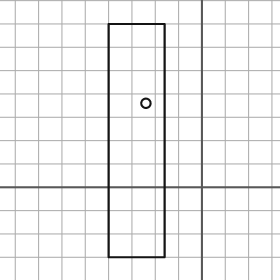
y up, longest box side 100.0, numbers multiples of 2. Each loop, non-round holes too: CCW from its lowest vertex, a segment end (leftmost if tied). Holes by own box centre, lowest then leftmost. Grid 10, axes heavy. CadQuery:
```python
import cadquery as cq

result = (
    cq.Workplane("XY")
    .moveTo(-40.0, -30.0)
    .lineTo(-16.0, -30.0)
    .lineTo(-16.0, 70.0)
    .lineTo(-40.0, 70.0)
    .close()
    .moveTo(-24.0, 36.0)
    .circle(2.0)
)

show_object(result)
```